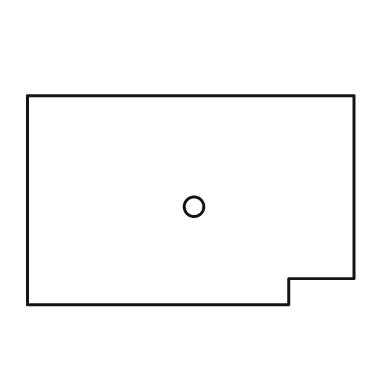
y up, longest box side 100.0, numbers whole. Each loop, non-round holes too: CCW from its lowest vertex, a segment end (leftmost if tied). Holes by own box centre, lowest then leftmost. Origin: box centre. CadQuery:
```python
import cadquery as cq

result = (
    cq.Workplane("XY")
    .moveTo(-50.0, -32.0)
    .lineTo(30.0, -32.0)
    .lineTo(30.0, -24.0)
    .lineTo(50.0, -24.0)
    .lineTo(50.0, 32.0)
    .lineTo(-50.0, 32.0)
    .close()
    .moveTo(1.0, -2.0)
    .circle(3.0)
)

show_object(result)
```